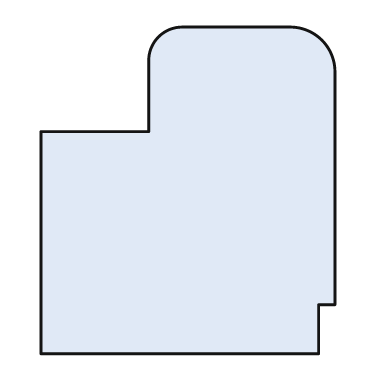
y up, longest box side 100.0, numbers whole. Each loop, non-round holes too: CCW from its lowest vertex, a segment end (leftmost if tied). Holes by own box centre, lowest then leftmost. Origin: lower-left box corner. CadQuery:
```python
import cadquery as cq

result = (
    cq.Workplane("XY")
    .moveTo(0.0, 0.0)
    .lineTo(85.0, 0.0)
    .lineTo(85.0, 15.0)
    .lineTo(90.0, 15.0)
    .lineTo(90.0, 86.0)
    .threePointArc((86.0, 96.0), (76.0, 100.0))
    .lineTo(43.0, 100.0)
    .threePointArc((36.0, 97.0), (33.0, 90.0))
    .lineTo(33.0, 68.0)
    .lineTo(0.0, 68.0)
    .close()
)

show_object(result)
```